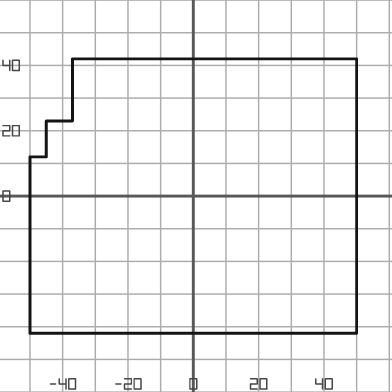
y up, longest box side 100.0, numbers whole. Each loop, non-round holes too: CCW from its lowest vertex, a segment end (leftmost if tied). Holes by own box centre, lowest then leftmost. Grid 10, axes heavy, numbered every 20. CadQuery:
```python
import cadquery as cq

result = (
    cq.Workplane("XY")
    .moveTo(-50.0, -42.0)
    .lineTo(50.0, -42.0)
    .lineTo(50.0, 42.0)
    .lineTo(-37.0, 42.0)
    .lineTo(-37.0, 23.0)
    .lineTo(-45.0, 23.0)
    .lineTo(-45.0, 12.0)
    .lineTo(-50.0, 12.0)
    .close()
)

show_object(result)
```